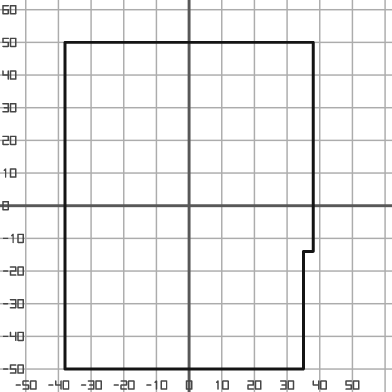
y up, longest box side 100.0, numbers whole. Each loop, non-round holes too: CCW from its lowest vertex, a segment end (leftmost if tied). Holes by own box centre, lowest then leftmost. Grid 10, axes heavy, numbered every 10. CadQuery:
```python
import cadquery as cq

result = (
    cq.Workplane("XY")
    .moveTo(-38.0, -50.0)
    .lineTo(35.0, -50.0)
    .lineTo(35.0, -14.0)
    .lineTo(38.0, -14.0)
    .lineTo(38.0, 50.0)
    .lineTo(-38.0, 50.0)
    .close()
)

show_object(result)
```